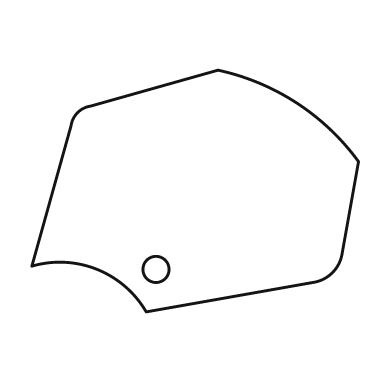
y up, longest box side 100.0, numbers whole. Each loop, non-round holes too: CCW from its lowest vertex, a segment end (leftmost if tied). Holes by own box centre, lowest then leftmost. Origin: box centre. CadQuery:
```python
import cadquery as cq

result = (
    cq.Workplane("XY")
    .moveTo(-15.0, -37.0)
    .lineTo(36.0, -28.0)
    .threePointArc((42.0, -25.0), (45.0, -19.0))
    .lineTo(50.0, 9.0)
    .threePointArc((31.0, 27.0), (7.0, 37.0))
    .lineTo(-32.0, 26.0)
    .threePointArc((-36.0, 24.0), (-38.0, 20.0))
    .lineTo(-50.0, -23.0)
    .threePointArc((-30.0, -24.0), (-15.0, -37.0))
    .close()
    .moveTo(-12.0, -24.0)
    .circle(4.0)
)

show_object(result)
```